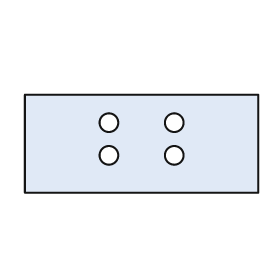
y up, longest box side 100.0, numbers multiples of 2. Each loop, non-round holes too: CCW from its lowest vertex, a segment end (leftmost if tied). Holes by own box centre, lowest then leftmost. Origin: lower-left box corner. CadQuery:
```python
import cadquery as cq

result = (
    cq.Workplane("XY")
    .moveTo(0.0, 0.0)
    .lineTo(100.0, 0.0)
    .lineTo(100.0, 42.0)
    .lineTo(0.0, 42.0)
    .close()
    .moveTo(36.0, 16.0)
    .circle(4.0)
    .moveTo(64.0, 16.0)
    .circle(4.0)
    .moveTo(36.0, 30.0)
    .circle(4.0)
    .moveTo(64.0, 30.0)
    .circle(4.0)
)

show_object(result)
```